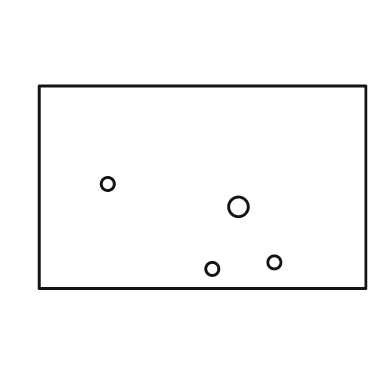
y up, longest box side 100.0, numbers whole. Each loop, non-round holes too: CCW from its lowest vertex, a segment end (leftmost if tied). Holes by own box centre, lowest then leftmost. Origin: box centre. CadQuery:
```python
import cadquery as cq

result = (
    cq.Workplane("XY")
    .moveTo(-50.0, -31.0)
    .lineTo(50.0, -31.0)
    .lineTo(50.0, 31.0)
    .lineTo(-50.0, 31.0)
    .close()
    .moveTo(3.0, -25.0)
    .circle(2.0)
    .moveTo(22.0, -23.0)
    .circle(2.0)
    .moveTo(11.0, -6.0)
    .circle(3.0)
    .moveTo(-29.0, 1.0)
    .circle(2.0)
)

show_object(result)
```